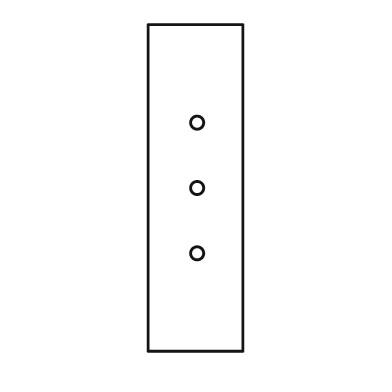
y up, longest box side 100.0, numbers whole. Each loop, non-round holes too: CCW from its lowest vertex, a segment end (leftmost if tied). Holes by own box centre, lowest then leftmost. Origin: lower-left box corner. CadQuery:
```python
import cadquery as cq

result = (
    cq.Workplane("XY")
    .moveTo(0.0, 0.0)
    .lineTo(29.0, 0.0)
    .lineTo(29.0, 100.0)
    .lineTo(0.0, 100.0)
    .close()
    .moveTo(15.0, 30.0)
    .circle(2.0)
    .moveTo(15.0, 50.0)
    .circle(2.0)
    .moveTo(15.0, 70.0)
    .circle(2.0)
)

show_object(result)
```